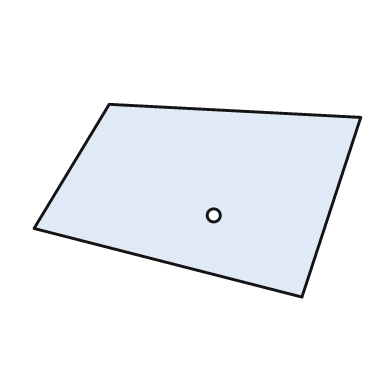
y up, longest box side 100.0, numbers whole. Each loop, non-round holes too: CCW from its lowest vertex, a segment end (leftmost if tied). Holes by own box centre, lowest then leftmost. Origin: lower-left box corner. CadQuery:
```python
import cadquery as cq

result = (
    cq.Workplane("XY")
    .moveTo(82.0, 0.0)
    .lineTo(100.0, 55.0)
    .lineTo(23.0, 59.0)
    .lineTo(0.0, 21.0)
    .close()
    .moveTo(55.0, 25.0)
    .circle(2.0)
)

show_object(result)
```